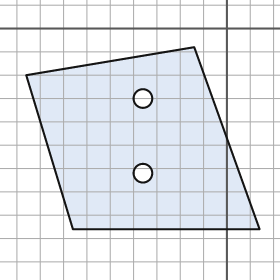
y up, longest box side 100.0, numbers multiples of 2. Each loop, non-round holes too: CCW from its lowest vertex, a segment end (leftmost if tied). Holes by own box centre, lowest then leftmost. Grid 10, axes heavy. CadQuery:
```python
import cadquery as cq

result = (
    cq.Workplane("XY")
    .moveTo(-66.0, -86.0)
    .lineTo(14.0, -86.0)
    .lineTo(-14.0, -8.0)
    .lineTo(-86.0, -20.0)
    .close()
    .moveTo(-36.0, -62.0)
    .circle(4.0)
    .moveTo(-36.0, -30.0)
    .circle(4.0)
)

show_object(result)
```